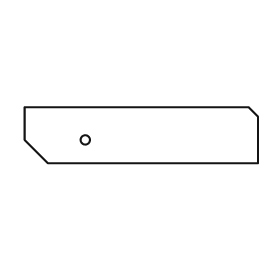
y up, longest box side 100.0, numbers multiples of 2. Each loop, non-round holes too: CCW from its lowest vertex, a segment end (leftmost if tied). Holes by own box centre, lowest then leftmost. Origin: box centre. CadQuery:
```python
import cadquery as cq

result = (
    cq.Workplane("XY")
    .moveTo(-40.0, -12.0)
    .lineTo(50.0, -12.0)
    .lineTo(50.0, 8.0)
    .lineTo(46.0, 12.0)
    .lineTo(-50.0, 12.0)
    .lineTo(-50.0, -2.0)
    .close()
    .moveTo(-24.0, -2.0)
    .circle(2.0)
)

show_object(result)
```